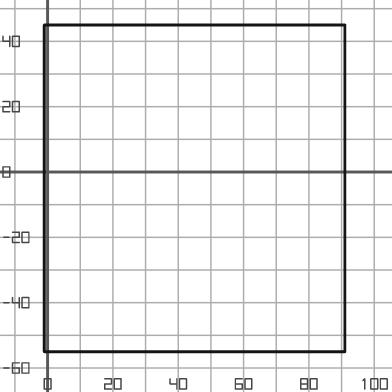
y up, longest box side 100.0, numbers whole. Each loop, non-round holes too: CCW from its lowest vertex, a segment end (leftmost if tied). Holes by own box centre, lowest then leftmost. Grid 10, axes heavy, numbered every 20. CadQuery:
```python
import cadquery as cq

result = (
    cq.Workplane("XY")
    .moveTo(-1.0, -55.0)
    .lineTo(91.0, -55.0)
    .lineTo(91.0, 45.0)
    .lineTo(-1.0, 45.0)
    .close()
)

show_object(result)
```